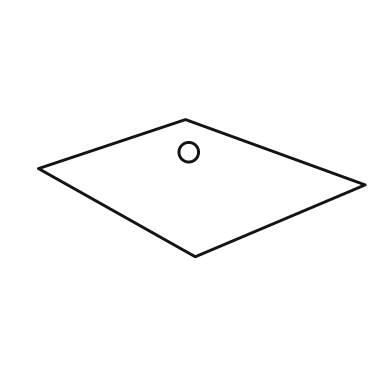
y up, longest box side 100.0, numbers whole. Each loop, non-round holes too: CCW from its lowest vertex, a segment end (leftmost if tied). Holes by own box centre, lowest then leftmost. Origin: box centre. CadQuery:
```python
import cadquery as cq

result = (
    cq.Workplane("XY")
    .moveTo(-2.0, -21.0)
    .lineTo(50.0, 1.0)
    .lineTo(-5.0, 21.0)
    .lineTo(-50.0, 6.0)
    .close()
    .moveTo(-4.0, 11.0)
    .circle(3.0)
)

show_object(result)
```